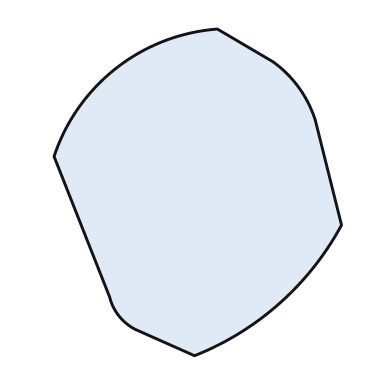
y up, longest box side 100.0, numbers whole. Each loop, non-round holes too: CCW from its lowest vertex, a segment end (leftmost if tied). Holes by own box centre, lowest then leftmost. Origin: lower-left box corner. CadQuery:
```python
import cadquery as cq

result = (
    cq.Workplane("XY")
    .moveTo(43.0, 0.0)
    .threePointArc((69.0, 16.0), (88.0, 40.0))
    .lineTo(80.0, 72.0)
    .threePointArc((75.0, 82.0), (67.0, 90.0))
    .lineTo(50.0, 100.0)
    .threePointArc((19.0, 88.0), (0.0, 61.0))
    .lineTo(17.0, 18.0)
    .threePointArc((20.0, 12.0), (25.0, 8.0))
    .close()
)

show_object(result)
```